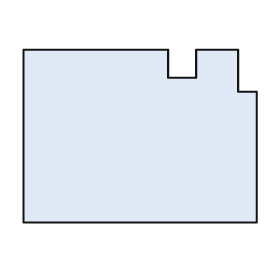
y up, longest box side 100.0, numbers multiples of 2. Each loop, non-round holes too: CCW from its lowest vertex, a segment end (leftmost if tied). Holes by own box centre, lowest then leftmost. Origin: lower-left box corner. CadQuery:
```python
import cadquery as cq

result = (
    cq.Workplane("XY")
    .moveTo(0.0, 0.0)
    .lineTo(100.0, 0.0)
    .lineTo(100.0, 56.0)
    .lineTo(92.0, 56.0)
    .lineTo(92.0, 74.0)
    .lineTo(74.0, 74.0)
    .lineTo(74.0, 62.0)
    .lineTo(62.0, 62.0)
    .lineTo(62.0, 74.0)
    .lineTo(0.0, 74.0)
    .close()
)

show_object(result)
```